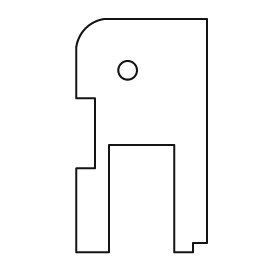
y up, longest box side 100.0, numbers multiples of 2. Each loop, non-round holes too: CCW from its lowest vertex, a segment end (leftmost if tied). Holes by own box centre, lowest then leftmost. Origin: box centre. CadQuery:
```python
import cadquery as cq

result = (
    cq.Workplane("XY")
    .moveTo(-28.0, -50.0)
    .lineTo(-14.0, -50.0)
    .lineTo(-14.0, -4.0)
    .lineTo(14.0, -4.0)
    .lineTo(14.0, -50.0)
    .lineTo(22.0, -50.0)
    .lineTo(22.0, -46.0)
    .lineTo(28.0, -46.0)
    .lineTo(28.0, 50.0)
    .lineTo(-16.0, 50.0)
    .threePointArc((-24.0, 46.0), (-28.0, 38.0))
    .lineTo(-28.0, 16.0)
    .lineTo(-20.0, 16.0)
    .lineTo(-20.0, -14.0)
    .lineTo(-28.0, -14.0)
    .close()
    .moveTo(-6.0, 28.0)
    .circle(4.0)
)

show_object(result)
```